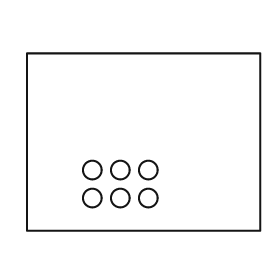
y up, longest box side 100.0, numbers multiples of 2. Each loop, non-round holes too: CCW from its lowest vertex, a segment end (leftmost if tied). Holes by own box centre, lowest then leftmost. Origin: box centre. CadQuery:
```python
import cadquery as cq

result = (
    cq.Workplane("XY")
    .moveTo(-50.0, -38.0)
    .lineTo(50.0, -38.0)
    .lineTo(50.0, 38.0)
    .lineTo(-50.0, 38.0)
    .close()
    .moveTo(-22.0, -24.0)
    .circle(4.0)
    .moveTo(-10.0, -24.0)
    .circle(4.0)
    .moveTo(2.0, -24.0)
    .circle(4.0)
    .moveTo(-22.0, -12.0)
    .circle(4.0)
    .moveTo(-10.0, -12.0)
    .circle(4.0)
    .moveTo(2.0, -12.0)
    .circle(4.0)
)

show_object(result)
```